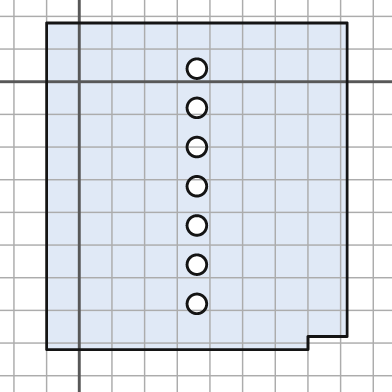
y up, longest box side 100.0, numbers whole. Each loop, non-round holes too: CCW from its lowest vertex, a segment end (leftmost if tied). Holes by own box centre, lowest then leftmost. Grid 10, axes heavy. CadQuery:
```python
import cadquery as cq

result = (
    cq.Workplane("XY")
    .moveTo(-10.0, -82.0)
    .lineTo(70.0, -82.0)
    .lineTo(70.0, -78.0)
    .lineTo(82.0, -78.0)
    .lineTo(82.0, 18.0)
    .lineTo(-10.0, 18.0)
    .close()
    .moveTo(36.0, -68.0)
    .circle(3.0)
    .moveTo(36.0, -56.0)
    .circle(3.0)
    .moveTo(36.0, -44.0)
    .circle(3.0)
    .moveTo(36.0, -32.0)
    .circle(3.0)
    .moveTo(36.0, -20.0)
    .circle(3.0)
    .moveTo(36.0, -8.0)
    .circle(3.0)
    .moveTo(36.0, 4.0)
    .circle(3.0)
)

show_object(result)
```